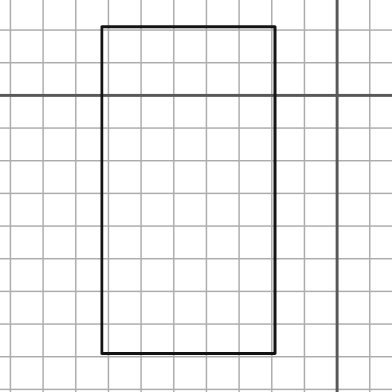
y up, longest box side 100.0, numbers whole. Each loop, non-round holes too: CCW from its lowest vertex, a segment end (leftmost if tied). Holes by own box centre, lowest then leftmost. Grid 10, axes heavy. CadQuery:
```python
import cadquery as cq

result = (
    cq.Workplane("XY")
    .moveTo(-72.0, -79.0)
    .lineTo(-19.0, -79.0)
    .lineTo(-19.0, 21.0)
    .lineTo(-72.0, 21.0)
    .close()
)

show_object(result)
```